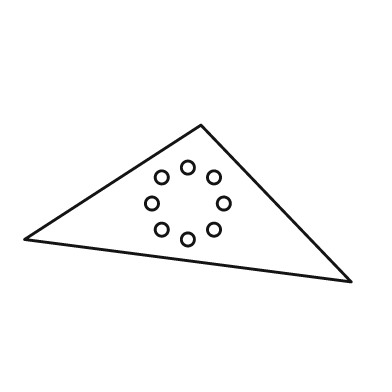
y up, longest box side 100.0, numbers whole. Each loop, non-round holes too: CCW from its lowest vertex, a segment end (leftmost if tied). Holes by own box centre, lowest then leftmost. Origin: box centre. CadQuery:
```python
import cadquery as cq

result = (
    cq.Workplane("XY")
    .moveTo(50.0, -24.0)
    .lineTo(4.0, 24.0)
    .lineTo(-50.0, -11.0)
    .close()
    .moveTo(0.0, -11.0)
    .circle(2.0)
    .moveTo(-8.0, -8.0)
    .circle(2.0)
    .moveTo(8.0, -8.0)
    .circle(2.0)
    .moveTo(-11.0, 0.0)
    .circle(2.0)
    .moveTo(11.0, 0.0)
    .circle(2.0)
    .moveTo(-8.0, 8.0)
    .circle(2.0)
    .moveTo(8.0, 8.0)
    .circle(2.0)
    .moveTo(0.0, 11.0)
    .circle(2.0)
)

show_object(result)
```